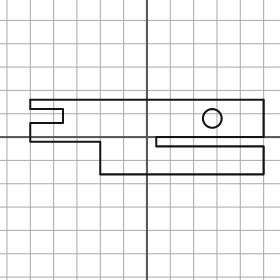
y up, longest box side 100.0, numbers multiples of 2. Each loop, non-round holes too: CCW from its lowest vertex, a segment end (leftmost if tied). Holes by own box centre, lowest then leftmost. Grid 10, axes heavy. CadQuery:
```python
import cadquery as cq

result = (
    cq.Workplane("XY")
    .moveTo(-20.0, -16.0)
    .lineTo(50.0, -16.0)
    .lineTo(50.0, -4.0)
    .lineTo(4.0, -4.0)
    .lineTo(4.0, 0.0)
    .lineTo(50.0, 0.0)
    .lineTo(50.0, 16.0)
    .lineTo(-50.0, 16.0)
    .lineTo(-50.0, 12.0)
    .lineTo(-36.0, 12.0)
    .lineTo(-36.0, 6.0)
    .lineTo(-50.0, 6.0)
    .lineTo(-50.0, -2.0)
    .lineTo(-20.0, -2.0)
    .close()
    .moveTo(28.0, 8.0)
    .circle(4.0)
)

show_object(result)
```